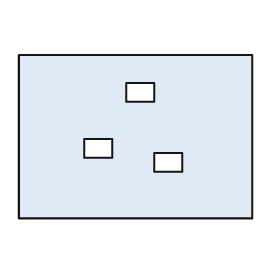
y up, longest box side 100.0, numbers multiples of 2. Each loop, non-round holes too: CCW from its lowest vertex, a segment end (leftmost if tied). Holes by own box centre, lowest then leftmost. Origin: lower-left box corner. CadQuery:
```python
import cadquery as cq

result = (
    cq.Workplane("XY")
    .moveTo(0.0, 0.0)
    .lineTo(100.0, 0.0)
    .lineTo(100.0, 70.0)
    .lineTo(0.0, 70.0)
    .close()
    .moveTo(58.0, 20.0)
    .lineTo(70.0, 20.0)
    .lineTo(70.0, 28.0)
    .lineTo(58.0, 28.0)
    .close()
    .moveTo(28.0, 26.0)
    .lineTo(40.0, 26.0)
    .lineTo(40.0, 34.0)
    .lineTo(28.0, 34.0)
    .close()
    .moveTo(46.0, 50.0)
    .lineTo(58.0, 50.0)
    .lineTo(58.0, 58.0)
    .lineTo(46.0, 58.0)
    .close()
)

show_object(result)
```